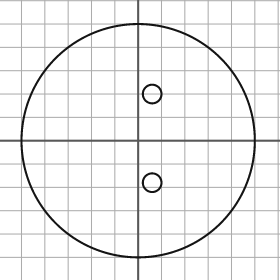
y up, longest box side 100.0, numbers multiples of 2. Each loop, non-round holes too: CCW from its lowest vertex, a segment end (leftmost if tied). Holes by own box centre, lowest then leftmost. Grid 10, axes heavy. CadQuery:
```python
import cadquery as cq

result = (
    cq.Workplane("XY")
    .moveTo(0.0, 0.0)
    .circle(50.0)
    .moveTo(6.0, -18.0)
    .circle(4.0)
    .moveTo(6.0, 20.0)
    .circle(4.0)
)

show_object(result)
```